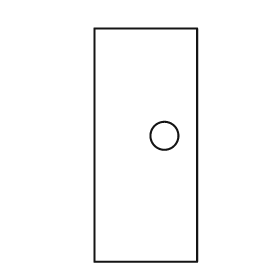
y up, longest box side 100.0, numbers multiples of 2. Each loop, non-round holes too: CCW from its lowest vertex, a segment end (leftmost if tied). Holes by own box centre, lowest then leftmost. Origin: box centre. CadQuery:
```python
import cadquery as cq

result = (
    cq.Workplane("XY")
    .moveTo(-22.0, -50.0)
    .lineTo(22.0, -50.0)
    .lineTo(22.0, 50.0)
    .lineTo(-22.0, 50.0)
    .close()
    .moveTo(8.0, 4.0)
    .circle(6.0)
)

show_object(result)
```